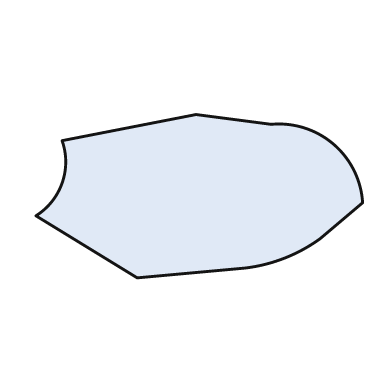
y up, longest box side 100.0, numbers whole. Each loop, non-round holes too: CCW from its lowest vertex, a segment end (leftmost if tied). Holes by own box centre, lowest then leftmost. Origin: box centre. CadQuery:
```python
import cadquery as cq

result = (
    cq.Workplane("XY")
    .moveTo(-19.0, -25.0)
    .lineTo(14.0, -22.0)
    .threePointArc((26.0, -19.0), (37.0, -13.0))
    .lineTo(50.0, -2.0)
    .threePointArc((41.0, 16.0), (22.0, 22.0))
    .lineTo(-1.0, 25.0)
    .lineTo(-42.0, 17.0)
    .threePointArc((-42.0, 4.0), (-50.0, -6.0))
    .close()
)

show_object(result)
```